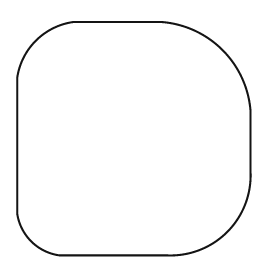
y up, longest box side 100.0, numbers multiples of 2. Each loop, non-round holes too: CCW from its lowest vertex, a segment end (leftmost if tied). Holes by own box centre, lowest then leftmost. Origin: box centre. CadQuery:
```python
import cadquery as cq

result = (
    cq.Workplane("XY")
    .moveTo(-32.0, -50.0)
    .lineTo(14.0, -50.0)
    .threePointArc((40.0, -40.0), (50.0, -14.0))
    .lineTo(50.0, 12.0)
    .threePointArc((38.0, 38.0), (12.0, 50.0))
    .lineTo(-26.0, 50.0)
    .threePointArc((-42.0, 42.0), (-50.0, 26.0))
    .lineTo(-50.0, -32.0)
    .threePointArc((-44.0, -44.0), (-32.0, -50.0))
    .close()
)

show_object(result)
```